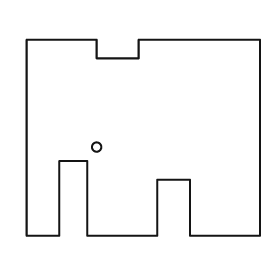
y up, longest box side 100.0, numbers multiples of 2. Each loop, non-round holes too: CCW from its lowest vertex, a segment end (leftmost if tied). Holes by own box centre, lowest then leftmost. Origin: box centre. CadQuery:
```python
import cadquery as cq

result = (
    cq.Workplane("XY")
    .moveTo(-50.0, -42.0)
    .lineTo(-36.0, -42.0)
    .lineTo(-36.0, -10.0)
    .lineTo(-24.0, -10.0)
    .lineTo(-24.0, -42.0)
    .lineTo(6.0, -42.0)
    .lineTo(6.0, -18.0)
    .lineTo(20.0, -18.0)
    .lineTo(20.0, -42.0)
    .lineTo(50.0, -42.0)
    .lineTo(50.0, 42.0)
    .lineTo(-2.0, 42.0)
    .lineTo(-2.0, 34.0)
    .lineTo(-20.0, 34.0)
    .lineTo(-20.0, 42.0)
    .lineTo(-50.0, 42.0)
    .close()
    .moveTo(-20.0, -4.0)
    .circle(2.0)
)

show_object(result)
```